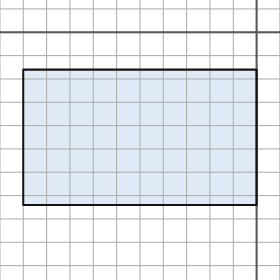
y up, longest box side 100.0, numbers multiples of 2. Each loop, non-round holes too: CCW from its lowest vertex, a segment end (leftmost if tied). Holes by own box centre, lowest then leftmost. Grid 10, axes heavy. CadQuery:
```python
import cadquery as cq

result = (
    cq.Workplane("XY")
    .moveTo(-100.0, -74.0)
    .lineTo(0.0, -74.0)
    .lineTo(0.0, -16.0)
    .lineTo(-100.0, -16.0)
    .close()
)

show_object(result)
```